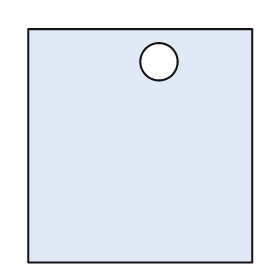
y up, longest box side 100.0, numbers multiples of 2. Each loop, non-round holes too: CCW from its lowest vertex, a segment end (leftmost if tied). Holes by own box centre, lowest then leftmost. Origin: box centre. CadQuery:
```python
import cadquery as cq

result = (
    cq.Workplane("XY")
    .moveTo(-48.0, -50.0)
    .lineTo(48.0, -50.0)
    .lineTo(48.0, 50.0)
    .lineTo(-48.0, 50.0)
    .close()
    .moveTo(8.0, 36.0)
    .circle(8.0)
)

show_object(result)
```